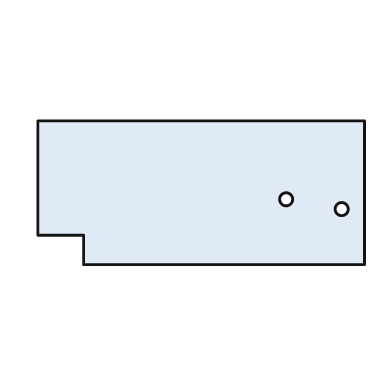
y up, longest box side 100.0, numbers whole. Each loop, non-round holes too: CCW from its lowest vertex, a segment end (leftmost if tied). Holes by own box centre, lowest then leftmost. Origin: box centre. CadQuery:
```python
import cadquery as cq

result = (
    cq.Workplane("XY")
    .moveTo(-36.0, -22.0)
    .lineTo(50.0, -22.0)
    .lineTo(50.0, 22.0)
    .lineTo(-50.0, 22.0)
    .lineTo(-50.0, -13.0)
    .lineTo(-36.0, -13.0)
    .close()
    .moveTo(43.0, -5.0)
    .circle(2.0)
    .moveTo(26.0, -2.0)
    .circle(2.0)
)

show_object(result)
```